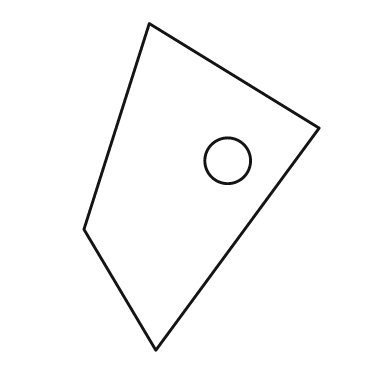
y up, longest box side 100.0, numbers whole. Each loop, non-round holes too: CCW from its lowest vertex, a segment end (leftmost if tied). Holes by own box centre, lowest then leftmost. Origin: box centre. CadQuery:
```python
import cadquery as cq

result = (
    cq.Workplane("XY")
    .moveTo(-14.0, -50.0)
    .lineTo(36.0, 18.0)
    .lineTo(-16.0, 50.0)
    .lineTo(-36.0, -13.0)
    .close()
    .moveTo(8.0, 8.0)
    .circle(7.0)
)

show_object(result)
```